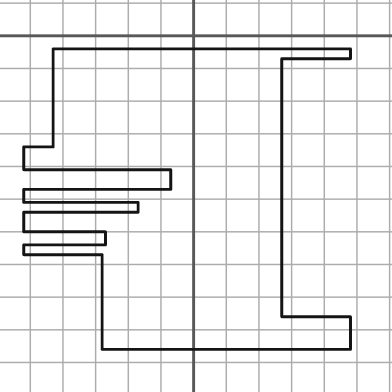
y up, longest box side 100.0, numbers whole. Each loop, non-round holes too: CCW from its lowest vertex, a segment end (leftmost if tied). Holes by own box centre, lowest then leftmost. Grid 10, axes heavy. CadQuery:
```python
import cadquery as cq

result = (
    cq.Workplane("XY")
    .moveTo(-28.0, -96.0)
    .lineTo(48.0, -96.0)
    .lineTo(48.0, -86.0)
    .lineTo(27.0, -86.0)
    .lineTo(27.0, -7.0)
    .lineTo(48.0, -7.0)
    .lineTo(48.0, -4.0)
    .lineTo(-43.0, -4.0)
    .lineTo(-43.0, -34.0)
    .lineTo(-52.0, -34.0)
    .lineTo(-52.0, -41.0)
    .lineTo(-7.0, -41.0)
    .lineTo(-7.0, -47.0)
    .lineTo(-52.0, -47.0)
    .lineTo(-52.0, -51.0)
    .lineTo(-17.0, -51.0)
    .lineTo(-17.0, -54.0)
    .lineTo(-52.0, -54.0)
    .lineTo(-52.0, -60.0)
    .lineTo(-27.0, -60.0)
    .lineTo(-27.0, -64.0)
    .lineTo(-52.0, -64.0)
    .lineTo(-52.0, -67.0)
    .lineTo(-28.0, -67.0)
    .close()
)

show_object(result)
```